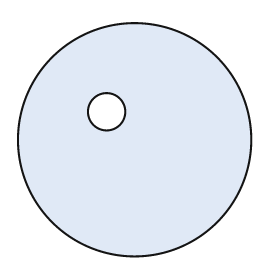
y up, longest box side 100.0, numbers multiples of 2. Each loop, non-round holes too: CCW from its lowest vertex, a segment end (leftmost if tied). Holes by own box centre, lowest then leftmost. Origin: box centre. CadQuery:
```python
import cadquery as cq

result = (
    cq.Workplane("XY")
    .moveTo(0.0, 0.0)
    .circle(50.0)
    .moveTo(-12.0, 12.0)
    .circle(8.0)
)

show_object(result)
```